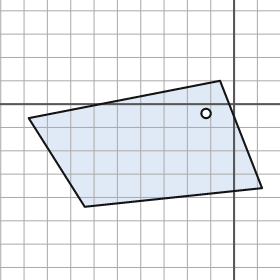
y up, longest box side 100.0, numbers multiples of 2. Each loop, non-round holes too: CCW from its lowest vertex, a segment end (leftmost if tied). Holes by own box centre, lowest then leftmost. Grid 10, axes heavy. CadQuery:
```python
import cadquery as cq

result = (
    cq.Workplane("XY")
    .moveTo(-64.0, -44.0)
    .lineTo(12.0, -36.0)
    .lineTo(-6.0, 10.0)
    .lineTo(-88.0, -6.0)
    .close()
    .moveTo(-12.0, -4.0)
    .circle(2.0)
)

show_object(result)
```